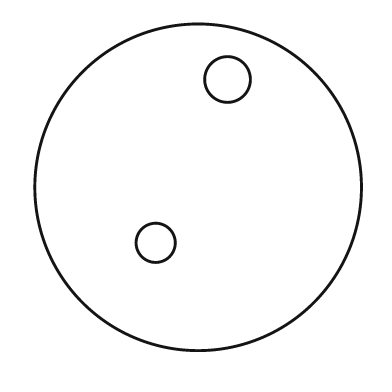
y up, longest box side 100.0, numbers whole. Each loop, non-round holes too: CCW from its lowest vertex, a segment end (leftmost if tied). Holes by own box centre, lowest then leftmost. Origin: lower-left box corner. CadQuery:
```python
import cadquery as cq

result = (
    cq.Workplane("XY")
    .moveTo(50.0, 50.0)
    .circle(50.0)
    .moveTo(37.0, 33.0)
    .circle(6.0)
    .moveTo(59.0, 83.0)
    .circle(7.0)
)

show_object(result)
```